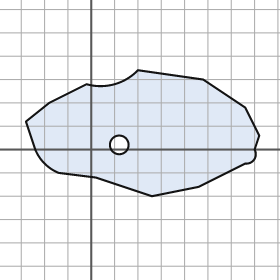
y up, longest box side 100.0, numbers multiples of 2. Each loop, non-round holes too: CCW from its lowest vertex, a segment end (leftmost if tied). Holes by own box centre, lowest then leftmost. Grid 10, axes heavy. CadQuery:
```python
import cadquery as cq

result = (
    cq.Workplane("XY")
    .moveTo(26.0, -20.0)
    .lineTo(46.0, -16.0)
    .lineTo(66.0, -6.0)
    .threePointArc((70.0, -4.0), (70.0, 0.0))
    .lineTo(72.0, 6.0)
    .lineTo(66.0, 18.0)
    .lineTo(48.0, 30.0)
    .lineTo(20.0, 34.0)
    .threePointArc((10.0, 28.0), (-2.0, 28.0))
    .lineTo(-18.0, 20.0)
    .lineTo(-28.0, 12.0)
    .lineTo(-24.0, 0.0)
    .threePointArc((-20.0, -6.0), (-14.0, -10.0))
    .lineTo(2.0, -12.0)
    .close()
    .moveTo(12.0, 2.0)
    .circle(4.0)
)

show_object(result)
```